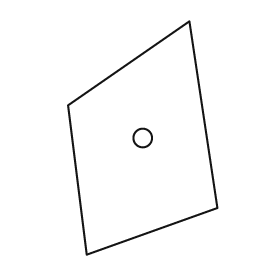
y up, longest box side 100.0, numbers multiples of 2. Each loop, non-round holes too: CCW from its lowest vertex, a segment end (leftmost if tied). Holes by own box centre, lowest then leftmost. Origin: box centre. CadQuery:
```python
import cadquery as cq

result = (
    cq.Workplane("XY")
    .moveTo(-24.0, -50.0)
    .lineTo(32.0, -30.0)
    .lineTo(20.0, 50.0)
    .lineTo(-32.0, 14.0)
    .close()
    .moveTo(0.0, 0.0)
    .circle(4.0)
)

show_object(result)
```